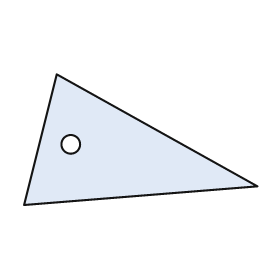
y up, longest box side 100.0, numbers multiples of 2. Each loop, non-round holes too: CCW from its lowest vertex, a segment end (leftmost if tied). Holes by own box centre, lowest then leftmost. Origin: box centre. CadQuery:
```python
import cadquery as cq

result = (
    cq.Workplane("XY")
    .moveTo(-50.0, -28.0)
    .lineTo(50.0, -20.0)
    .lineTo(-36.0, 28.0)
    .close()
    .moveTo(-30.0, -2.0)
    .circle(4.0)
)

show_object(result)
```